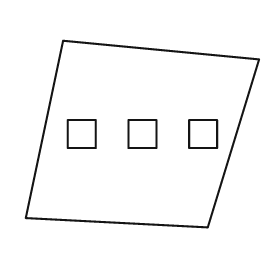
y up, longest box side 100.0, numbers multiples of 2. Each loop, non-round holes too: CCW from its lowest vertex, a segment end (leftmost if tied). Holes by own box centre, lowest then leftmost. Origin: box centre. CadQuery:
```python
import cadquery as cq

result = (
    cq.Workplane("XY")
    .moveTo(28.0, -40.0)
    .lineTo(50.0, 32.0)
    .lineTo(-34.0, 40.0)
    .lineTo(-50.0, -36.0)
    .close()
    .moveTo(-32.0, -6.0)
    .lineTo(-20.0, -6.0)
    .lineTo(-20.0, 6.0)
    .lineTo(-32.0, 6.0)
    .close()
    .moveTo(-6.0, -6.0)
    .lineTo(6.0, -6.0)
    .lineTo(6.0, 6.0)
    .lineTo(-6.0, 6.0)
    .close()
    .moveTo(20.0, -6.0)
    .lineTo(32.0, -6.0)
    .lineTo(32.0, 6.0)
    .lineTo(20.0, 6.0)
    .close()
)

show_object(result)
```